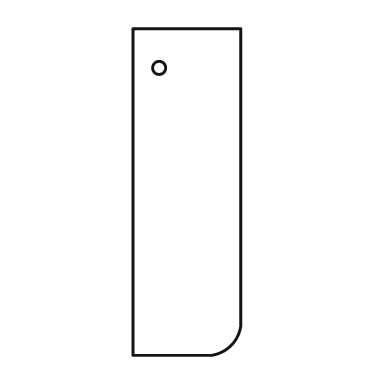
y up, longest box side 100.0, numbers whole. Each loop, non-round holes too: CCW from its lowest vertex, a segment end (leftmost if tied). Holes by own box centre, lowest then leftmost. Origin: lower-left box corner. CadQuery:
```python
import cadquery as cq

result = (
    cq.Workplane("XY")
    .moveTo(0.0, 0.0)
    .lineTo(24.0, 0.0)
    .threePointArc((30.0, 3.0), (33.0, 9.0))
    .lineTo(33.0, 100.0)
    .lineTo(0.0, 100.0)
    .close()
    .moveTo(8.0, 88.0)
    .circle(2.0)
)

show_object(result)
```